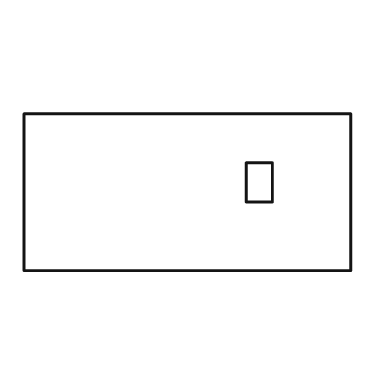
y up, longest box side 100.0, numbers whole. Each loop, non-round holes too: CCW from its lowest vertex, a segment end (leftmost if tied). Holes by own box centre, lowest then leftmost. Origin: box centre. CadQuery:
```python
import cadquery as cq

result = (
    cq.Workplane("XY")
    .moveTo(-50.0, -24.0)
    .lineTo(50.0, -24.0)
    .lineTo(50.0, 24.0)
    .lineTo(-50.0, 24.0)
    .close()
    .moveTo(18.0, -3.0)
    .lineTo(26.0, -3.0)
    .lineTo(26.0, 9.0)
    .lineTo(18.0, 9.0)
    .close()
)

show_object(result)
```